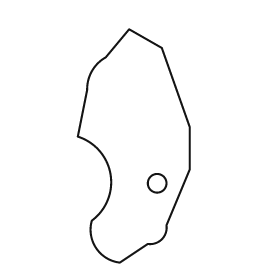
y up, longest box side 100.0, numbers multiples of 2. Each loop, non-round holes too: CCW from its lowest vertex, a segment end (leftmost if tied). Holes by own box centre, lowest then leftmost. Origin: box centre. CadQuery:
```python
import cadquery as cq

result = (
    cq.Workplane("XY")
    .moveTo(-6.0, -50.0)
    .lineTo(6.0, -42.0)
    .threePointArc((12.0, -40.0), (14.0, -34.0))
    .lineTo(24.0, -10.0)
    .lineTo(24.0, 8.0)
    .lineTo(12.0, 42.0)
    .lineTo(-2.0, 50.0)
    .lineTo(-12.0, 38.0)
    .threePointArc((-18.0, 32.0), (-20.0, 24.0))
    .lineTo(-24.0, 4.0)
    .threePointArc((-10.0, -12.0), (-18.0, -32.0))
    .threePointArc((-16.0, -44.0), (-6.0, -50.0))
    .close()
    .moveTo(10.0, -16.0)
    .circle(4.0)
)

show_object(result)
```